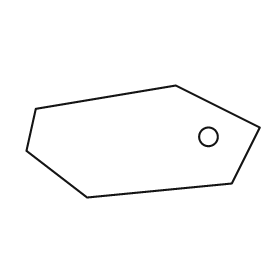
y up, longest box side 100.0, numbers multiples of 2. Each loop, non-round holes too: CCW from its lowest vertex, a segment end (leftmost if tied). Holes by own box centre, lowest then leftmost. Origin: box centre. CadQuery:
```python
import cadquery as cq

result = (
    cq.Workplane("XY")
    .moveTo(-24.0, -24.0)
    .lineTo(38.0, -18.0)
    .lineTo(50.0, 6.0)
    .lineTo(14.0, 24.0)
    .lineTo(-46.0, 14.0)
    .lineTo(-50.0, -4.0)
    .close()
    .moveTo(28.0, 2.0)
    .circle(4.0)
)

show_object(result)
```